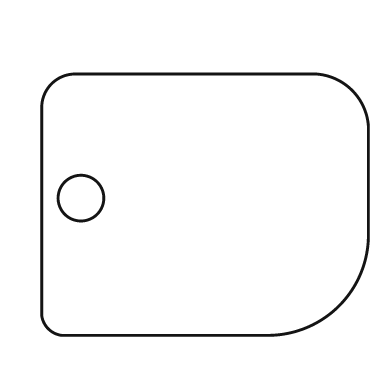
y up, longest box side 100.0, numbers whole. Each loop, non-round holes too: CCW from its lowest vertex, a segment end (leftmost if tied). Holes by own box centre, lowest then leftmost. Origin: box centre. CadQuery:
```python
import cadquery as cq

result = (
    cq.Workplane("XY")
    .moveTo(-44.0, -40.0)
    .lineTo(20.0, -40.0)
    .threePointArc((41.0, -31.0), (50.0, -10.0))
    .lineTo(50.0, 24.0)
    .threePointArc((45.0, 35.0), (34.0, 40.0))
    .lineTo(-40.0, 40.0)
    .threePointArc((-47.0, 37.0), (-50.0, 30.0))
    .lineTo(-50.0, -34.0)
    .threePointArc((-48.0, -38.0), (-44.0, -40.0))
    .close()
    .moveTo(-38.0, 2.0)
    .circle(7.0)
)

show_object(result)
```